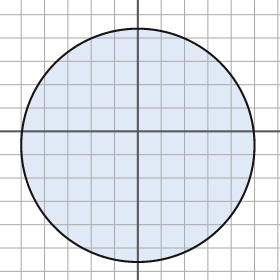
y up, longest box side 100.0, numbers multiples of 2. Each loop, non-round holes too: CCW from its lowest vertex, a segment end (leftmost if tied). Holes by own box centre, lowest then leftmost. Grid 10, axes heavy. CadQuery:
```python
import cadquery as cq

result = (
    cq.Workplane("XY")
    .moveTo(0.0, -6.0)
    .circle(50.0)
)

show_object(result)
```